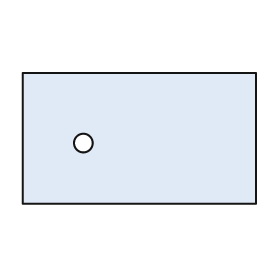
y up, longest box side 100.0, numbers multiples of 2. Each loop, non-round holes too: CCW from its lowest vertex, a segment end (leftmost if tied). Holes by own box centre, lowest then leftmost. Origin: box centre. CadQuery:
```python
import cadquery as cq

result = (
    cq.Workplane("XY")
    .moveTo(-50.0, -28.0)
    .lineTo(50.0, -28.0)
    .lineTo(50.0, 28.0)
    .lineTo(-50.0, 28.0)
    .close()
    .moveTo(-24.0, -2.0)
    .circle(4.0)
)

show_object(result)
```